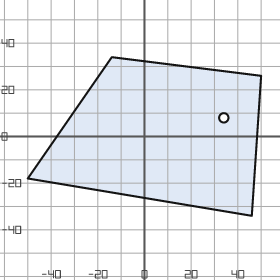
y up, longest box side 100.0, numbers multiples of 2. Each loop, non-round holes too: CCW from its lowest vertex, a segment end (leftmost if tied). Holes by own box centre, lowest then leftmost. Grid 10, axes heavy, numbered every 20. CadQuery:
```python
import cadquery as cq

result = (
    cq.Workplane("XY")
    .moveTo(46.0, -34.0)
    .lineTo(50.0, 26.0)
    .lineTo(-14.0, 34.0)
    .lineTo(-50.0, -18.0)
    .close()
    .moveTo(34.0, 8.0)
    .circle(2.0)
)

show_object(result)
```